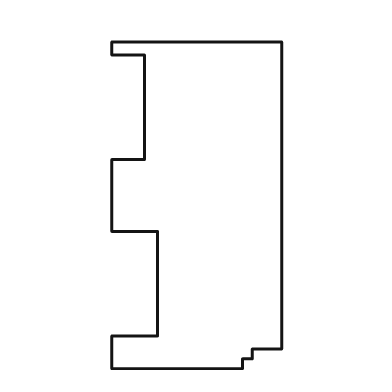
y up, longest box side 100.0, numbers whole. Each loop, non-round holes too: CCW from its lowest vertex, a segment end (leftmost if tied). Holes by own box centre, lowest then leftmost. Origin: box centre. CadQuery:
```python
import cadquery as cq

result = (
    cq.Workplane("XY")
    .moveTo(-26.0, -50.0)
    .lineTo(14.0, -50.0)
    .lineTo(14.0, -47.0)
    .lineTo(17.0, -47.0)
    .lineTo(17.0, -44.0)
    .lineTo(26.0, -44.0)
    .lineTo(26.0, 50.0)
    .lineTo(-26.0, 50.0)
    .lineTo(-26.0, 46.0)
    .lineTo(-16.0, 46.0)
    .lineTo(-16.0, 14.0)
    .lineTo(-26.0, 14.0)
    .lineTo(-26.0, -8.0)
    .lineTo(-12.0, -8.0)
    .lineTo(-12.0, -40.0)
    .lineTo(-26.0, -40.0)
    .close()
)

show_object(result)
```